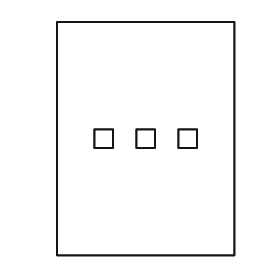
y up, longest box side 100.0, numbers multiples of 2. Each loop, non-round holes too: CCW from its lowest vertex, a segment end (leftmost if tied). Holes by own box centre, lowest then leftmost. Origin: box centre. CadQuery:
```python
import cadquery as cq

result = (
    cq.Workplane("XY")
    .moveTo(-38.0, -50.0)
    .lineTo(38.0, -50.0)
    .lineTo(38.0, 50.0)
    .lineTo(-38.0, 50.0)
    .close()
    .moveTo(-22.0, -4.0)
    .lineTo(-14.0, -4.0)
    .lineTo(-14.0, 4.0)
    .lineTo(-22.0, 4.0)
    .close()
    .moveTo(-4.0, -4.0)
    .lineTo(4.0, -4.0)
    .lineTo(4.0, 4.0)
    .lineTo(-4.0, 4.0)
    .close()
    .moveTo(14.0, -4.0)
    .lineTo(22.0, -4.0)
    .lineTo(22.0, 4.0)
    .lineTo(14.0, 4.0)
    .close()
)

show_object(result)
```